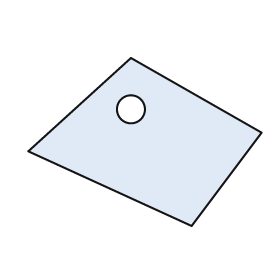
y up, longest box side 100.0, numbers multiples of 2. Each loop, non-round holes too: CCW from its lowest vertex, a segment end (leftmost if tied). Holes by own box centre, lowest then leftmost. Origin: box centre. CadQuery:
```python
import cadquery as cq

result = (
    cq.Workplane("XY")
    .moveTo(20.0, -36.0)
    .lineTo(50.0, 4.0)
    .lineTo(-6.0, 36.0)
    .lineTo(-50.0, -4.0)
    .close()
    .moveTo(-6.0, 14.0)
    .circle(6.0)
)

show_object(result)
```